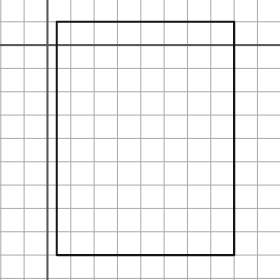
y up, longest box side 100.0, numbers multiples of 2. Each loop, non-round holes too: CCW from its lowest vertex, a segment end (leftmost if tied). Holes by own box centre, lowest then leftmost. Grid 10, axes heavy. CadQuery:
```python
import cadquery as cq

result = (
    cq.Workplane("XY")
    .moveTo(4.0, -90.0)
    .lineTo(80.0, -90.0)
    .lineTo(80.0, 10.0)
    .lineTo(4.0, 10.0)
    .close()
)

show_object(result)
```